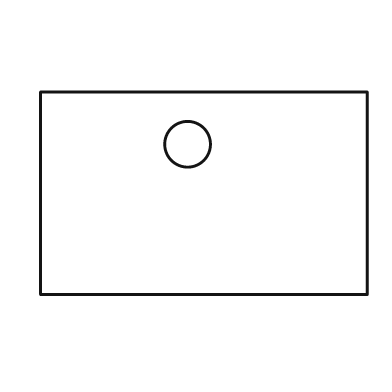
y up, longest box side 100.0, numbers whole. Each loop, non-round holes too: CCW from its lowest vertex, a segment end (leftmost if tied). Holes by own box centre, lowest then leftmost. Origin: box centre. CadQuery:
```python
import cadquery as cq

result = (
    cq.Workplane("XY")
    .moveTo(-50.0, -31.0)
    .lineTo(50.0, -31.0)
    .lineTo(50.0, 31.0)
    .lineTo(-50.0, 31.0)
    .close()
    .moveTo(-5.0, 15.0)
    .circle(7.0)
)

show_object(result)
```